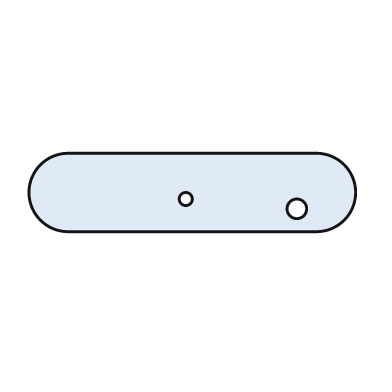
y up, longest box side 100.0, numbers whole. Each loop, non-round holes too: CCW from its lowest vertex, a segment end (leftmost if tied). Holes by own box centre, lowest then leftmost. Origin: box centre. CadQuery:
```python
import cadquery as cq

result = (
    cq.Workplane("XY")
    .moveTo(-38.0, -12.0)
    .lineTo(38.0, -12.0)
    .threePointArc((50.0, 0.0), (38.0, 12.0))
    .lineTo(-38.0, 12.0)
    .threePointArc((-50.0, 0.0), (-38.0, -12.0))
    .close()
    .moveTo(32.0, -5.0)
    .circle(3.0)
    .moveTo(-2.0, -2.0)
    .circle(2.0)
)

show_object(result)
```